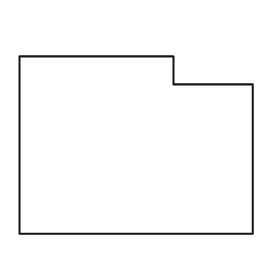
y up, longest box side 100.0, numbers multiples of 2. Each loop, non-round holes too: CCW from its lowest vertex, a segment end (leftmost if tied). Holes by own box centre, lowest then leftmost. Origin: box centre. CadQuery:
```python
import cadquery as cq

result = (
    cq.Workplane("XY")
    .moveTo(-50.0, -38.0)
    .lineTo(50.0, -38.0)
    .lineTo(50.0, 26.0)
    .lineTo(16.0, 26.0)
    .lineTo(16.0, 38.0)
    .lineTo(-50.0, 38.0)
    .close()
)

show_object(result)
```